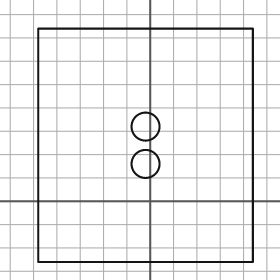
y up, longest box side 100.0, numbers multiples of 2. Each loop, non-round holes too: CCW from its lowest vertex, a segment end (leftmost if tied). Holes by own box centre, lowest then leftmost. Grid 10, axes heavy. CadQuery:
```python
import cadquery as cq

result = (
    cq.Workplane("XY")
    .moveTo(-48.0, -26.0)
    .lineTo(44.0, -26.0)
    .lineTo(44.0, 74.0)
    .lineTo(-48.0, 74.0)
    .close()
    .moveTo(-2.0, 16.0)
    .circle(6.0)
    .moveTo(-2.0, 32.0)
    .circle(6.0)
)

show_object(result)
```